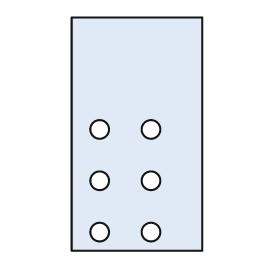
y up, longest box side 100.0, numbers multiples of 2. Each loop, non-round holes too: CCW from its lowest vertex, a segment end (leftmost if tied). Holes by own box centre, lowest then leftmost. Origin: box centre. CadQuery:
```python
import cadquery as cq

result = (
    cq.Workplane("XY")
    .moveTo(-28.0, -50.0)
    .lineTo(28.0, -50.0)
    .lineTo(28.0, 50.0)
    .lineTo(-28.0, 50.0)
    .close()
    .moveTo(-16.0, -42.0)
    .circle(4.0)
    .moveTo(6.0, -42.0)
    .circle(4.0)
    .moveTo(-16.0, -20.0)
    .circle(4.0)
    .moveTo(6.0, -20.0)
    .circle(4.0)
    .moveTo(-16.0, 2.0)
    .circle(4.0)
    .moveTo(6.0, 2.0)
    .circle(4.0)
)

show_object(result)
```